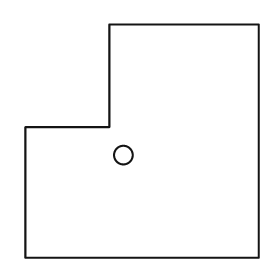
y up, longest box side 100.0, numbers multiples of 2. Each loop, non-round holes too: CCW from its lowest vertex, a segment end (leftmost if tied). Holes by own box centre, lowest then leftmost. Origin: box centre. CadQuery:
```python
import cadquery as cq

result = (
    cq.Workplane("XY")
    .moveTo(-50.0, -50.0)
    .lineTo(50.0, -50.0)
    .lineTo(50.0, 50.0)
    .lineTo(-14.0, 50.0)
    .lineTo(-14.0, 6.0)
    .lineTo(-50.0, 6.0)
    .close()
    .moveTo(-8.0, -6.0)
    .circle(4.0)
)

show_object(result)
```